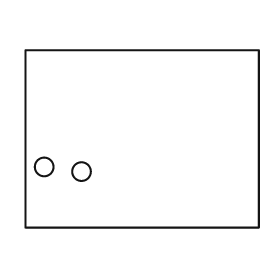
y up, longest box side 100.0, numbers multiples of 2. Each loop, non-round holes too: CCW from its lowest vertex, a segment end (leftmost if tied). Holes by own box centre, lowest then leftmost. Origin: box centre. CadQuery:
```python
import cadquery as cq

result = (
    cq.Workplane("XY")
    .moveTo(-50.0, -38.0)
    .lineTo(50.0, -38.0)
    .lineTo(50.0, 38.0)
    .lineTo(-50.0, 38.0)
    .close()
    .moveTo(-26.0, -14.0)
    .circle(4.0)
    .moveTo(-42.0, -12.0)
    .circle(4.0)
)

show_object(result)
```